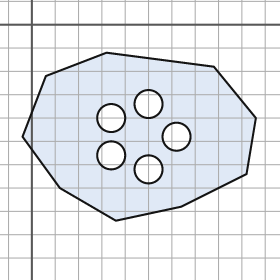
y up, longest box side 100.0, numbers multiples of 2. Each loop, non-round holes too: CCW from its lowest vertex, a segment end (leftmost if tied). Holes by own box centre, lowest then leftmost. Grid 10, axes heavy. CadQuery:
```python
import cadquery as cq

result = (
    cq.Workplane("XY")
    .moveTo(36.0, -84.0)
    .lineTo(64.0, -78.0)
    .lineTo(92.0, -64.0)
    .lineTo(96.0, -40.0)
    .lineTo(78.0, -18.0)
    .lineTo(32.0, -12.0)
    .lineTo(6.0, -22.0)
    .lineTo(-4.0, -48.0)
    .lineTo(12.0, -70.0)
    .close()
    .moveTo(50.0, -62.0)
    .circle(6.0)
    .moveTo(34.0, -56.0)
    .circle(6.0)
    .moveTo(62.0, -48.0)
    .circle(6.0)
    .moveTo(34.0, -40.0)
    .circle(6.0)
    .moveTo(50.0, -34.0)
    .circle(6.0)
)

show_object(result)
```